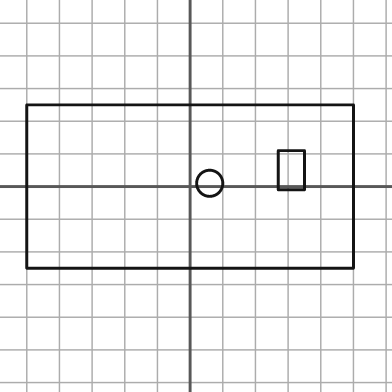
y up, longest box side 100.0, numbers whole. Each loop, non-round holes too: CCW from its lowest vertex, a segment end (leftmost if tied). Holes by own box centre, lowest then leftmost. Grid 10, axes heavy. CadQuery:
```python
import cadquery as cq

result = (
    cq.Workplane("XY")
    .moveTo(-50.0, -25.0)
    .lineTo(50.0, -25.0)
    .lineTo(50.0, 25.0)
    .lineTo(-50.0, 25.0)
    .close()
    .moveTo(6.0, 1.0)
    .circle(4.0)
    .moveTo(27.0, -1.0)
    .lineTo(35.0, -1.0)
    .lineTo(35.0, 11.0)
    .lineTo(27.0, 11.0)
    .close()
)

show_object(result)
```